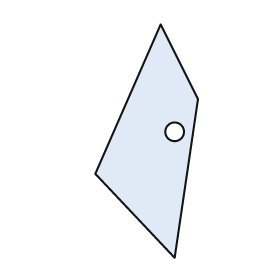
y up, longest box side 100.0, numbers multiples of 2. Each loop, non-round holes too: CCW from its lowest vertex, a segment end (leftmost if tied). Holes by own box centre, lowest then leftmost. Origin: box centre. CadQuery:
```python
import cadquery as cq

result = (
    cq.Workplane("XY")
    .moveTo(12.0, -50.0)
    .lineTo(22.0, 18.0)
    .lineTo(6.0, 50.0)
    .lineTo(-22.0, -14.0)
    .close()
    .moveTo(12.0, 4.0)
    .circle(4.0)
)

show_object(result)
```